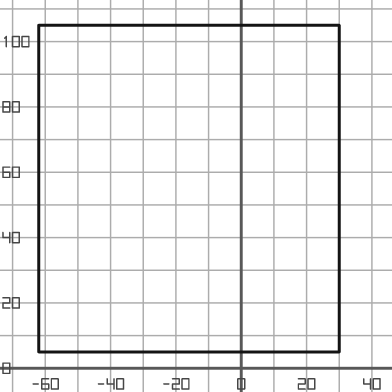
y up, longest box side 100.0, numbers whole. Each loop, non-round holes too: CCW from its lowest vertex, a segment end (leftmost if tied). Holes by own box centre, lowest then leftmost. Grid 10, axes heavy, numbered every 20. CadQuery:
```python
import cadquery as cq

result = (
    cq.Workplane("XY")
    .moveTo(-62.0, 5.0)
    .lineTo(30.0, 5.0)
    .lineTo(30.0, 105.0)
    .lineTo(-62.0, 105.0)
    .close()
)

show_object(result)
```